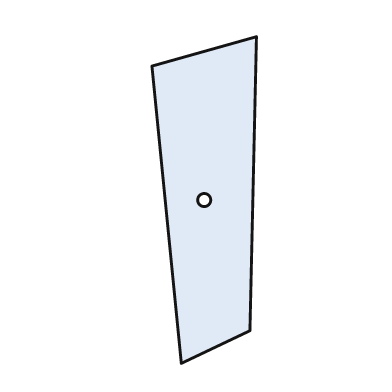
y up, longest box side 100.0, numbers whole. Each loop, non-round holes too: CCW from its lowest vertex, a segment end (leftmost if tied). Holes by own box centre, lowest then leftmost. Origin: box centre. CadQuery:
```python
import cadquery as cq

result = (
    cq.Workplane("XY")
    .moveTo(-7.0, -50.0)
    .lineTo(14.0, -40.0)
    .lineTo(16.0, 50.0)
    .lineTo(-16.0, 41.0)
    .close()
    .moveTo(0.0, 0.0)
    .circle(2.0)
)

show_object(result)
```